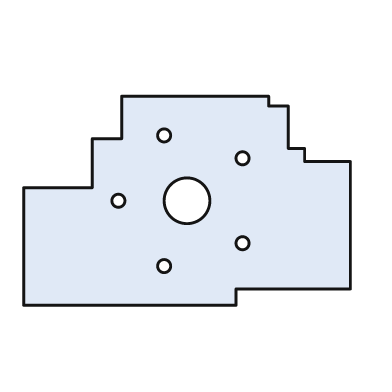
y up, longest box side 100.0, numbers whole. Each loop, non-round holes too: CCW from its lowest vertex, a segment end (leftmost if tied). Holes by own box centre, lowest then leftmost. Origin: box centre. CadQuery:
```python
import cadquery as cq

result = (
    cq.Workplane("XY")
    .moveTo(-50.0, -32.0)
    .lineTo(15.0, -32.0)
    .lineTo(15.0, -27.0)
    .lineTo(50.0, -27.0)
    .lineTo(50.0, 12.0)
    .lineTo(36.0, 12.0)
    .lineTo(36.0, 16.0)
    .lineTo(31.0, 16.0)
    .lineTo(31.0, 29.0)
    .lineTo(25.0, 29.0)
    .lineTo(25.0, 32.0)
    .lineTo(-20.0, 32.0)
    .lineTo(-20.0, 19.0)
    .lineTo(-29.0, 19.0)
    .lineTo(-29.0, 4.0)
    .lineTo(-50.0, 4.0)
    .close()
    .moveTo(-7.0, -20.0)
    .circle(2.0)
    .moveTo(17.0, -13.0)
    .circle(2.0)
    .moveTo(-21.0, 0.0)
    .circle(2.0)
    .moveTo(0.0, 0.0)
    .circle(7.0)
    .moveTo(17.0, 13.0)
    .circle(2.0)
    .moveTo(-7.0, 20.0)
    .circle(2.0)
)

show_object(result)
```